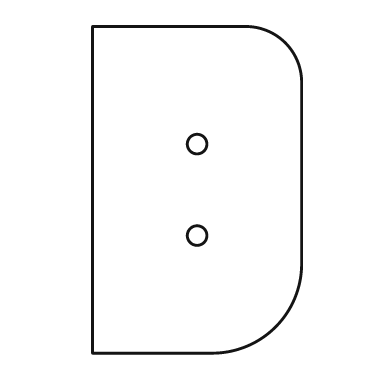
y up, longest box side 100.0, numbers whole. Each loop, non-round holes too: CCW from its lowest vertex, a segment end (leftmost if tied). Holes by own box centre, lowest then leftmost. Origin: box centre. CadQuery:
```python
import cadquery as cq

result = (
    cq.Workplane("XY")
    .moveTo(-32.0, -50.0)
    .lineTo(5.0, -50.0)
    .threePointArc((24.0, -42.0), (32.0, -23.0))
    .lineTo(32.0, 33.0)
    .threePointArc((27.0, 45.0), (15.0, 50.0))
    .lineTo(-32.0, 50.0)
    .close()
    .moveTo(0.0, -14.0)
    .circle(3.0)
    .moveTo(0.0, 14.0)
    .circle(3.0)
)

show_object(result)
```